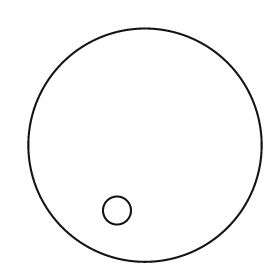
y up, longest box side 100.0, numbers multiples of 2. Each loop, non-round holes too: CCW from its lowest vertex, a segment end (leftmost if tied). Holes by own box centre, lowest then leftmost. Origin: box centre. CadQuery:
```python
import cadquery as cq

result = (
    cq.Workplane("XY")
    .moveTo(0.0, 0.0)
    .circle(50.0)
    .moveTo(-12.0, -28.0)
    .circle(6.0)
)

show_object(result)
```